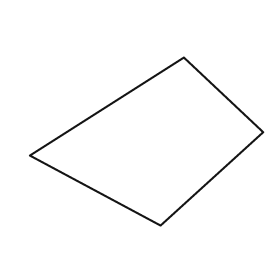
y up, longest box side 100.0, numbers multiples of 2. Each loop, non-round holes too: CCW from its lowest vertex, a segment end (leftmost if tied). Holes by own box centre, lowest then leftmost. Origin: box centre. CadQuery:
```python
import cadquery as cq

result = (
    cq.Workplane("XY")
    .moveTo(6.0, -36.0)
    .lineTo(50.0, 4.0)
    .lineTo(16.0, 36.0)
    .lineTo(-50.0, -6.0)
    .close()
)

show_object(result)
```